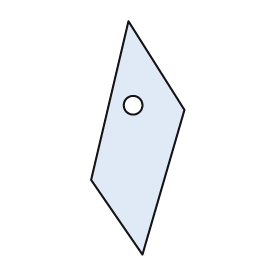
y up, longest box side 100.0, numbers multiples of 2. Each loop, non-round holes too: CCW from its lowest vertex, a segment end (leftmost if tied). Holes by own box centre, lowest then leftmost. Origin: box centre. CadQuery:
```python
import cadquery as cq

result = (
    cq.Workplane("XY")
    .moveTo(2.0, -50.0)
    .lineTo(20.0, 12.0)
    .lineTo(-4.0, 50.0)
    .lineTo(-20.0, -18.0)
    .close()
    .moveTo(-2.0, 14.0)
    .circle(4.0)
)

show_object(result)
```